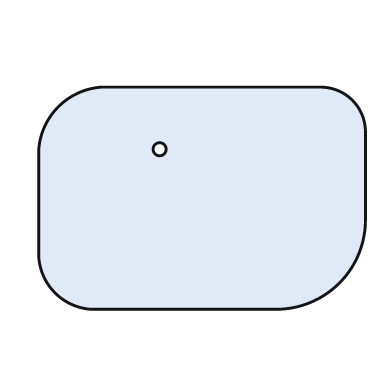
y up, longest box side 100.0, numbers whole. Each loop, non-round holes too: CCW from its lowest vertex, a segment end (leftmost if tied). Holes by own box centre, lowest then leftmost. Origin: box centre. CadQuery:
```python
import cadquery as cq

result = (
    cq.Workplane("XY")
    .moveTo(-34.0, -34.0)
    .lineTo(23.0, -34.0)
    .threePointArc((42.0, -26.0), (50.0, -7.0))
    .lineTo(50.0, 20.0)
    .threePointArc((46.0, 30.0), (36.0, 34.0))
    .lineTo(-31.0, 34.0)
    .threePointArc((-44.0, 28.0), (-50.0, 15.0))
    .lineTo(-50.0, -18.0)
    .threePointArc((-45.0, -29.0), (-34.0, -34.0))
    .close()
    .moveTo(-13.0, 15.0)
    .circle(2.0)
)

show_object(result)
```